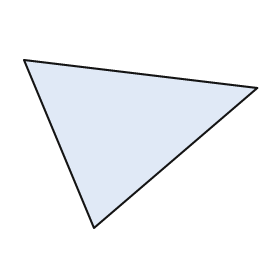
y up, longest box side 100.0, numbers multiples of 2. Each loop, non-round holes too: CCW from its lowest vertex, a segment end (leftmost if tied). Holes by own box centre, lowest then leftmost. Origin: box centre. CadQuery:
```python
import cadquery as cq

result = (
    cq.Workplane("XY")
    .moveTo(-20.0, -36.0)
    .lineTo(50.0, 24.0)
    .lineTo(-50.0, 36.0)
    .close()
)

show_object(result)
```